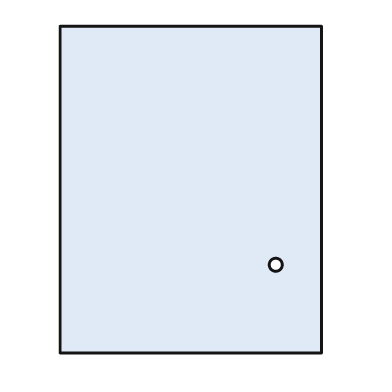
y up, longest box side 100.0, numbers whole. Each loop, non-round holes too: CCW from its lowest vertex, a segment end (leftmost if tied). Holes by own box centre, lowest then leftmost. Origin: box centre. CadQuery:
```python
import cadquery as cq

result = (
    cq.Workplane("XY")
    .moveTo(-40.0, -50.0)
    .lineTo(40.0, -50.0)
    .lineTo(40.0, 50.0)
    .lineTo(-40.0, 50.0)
    .close()
    .moveTo(26.0, -23.0)
    .circle(2.0)
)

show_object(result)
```